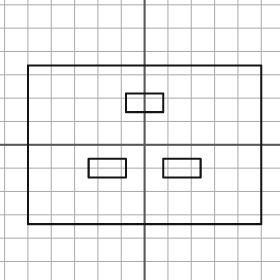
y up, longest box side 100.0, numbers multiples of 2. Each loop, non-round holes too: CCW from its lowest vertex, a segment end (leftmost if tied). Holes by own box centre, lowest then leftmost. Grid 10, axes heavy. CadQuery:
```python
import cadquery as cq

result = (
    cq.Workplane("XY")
    .moveTo(-50.0, -34.0)
    .lineTo(50.0, -34.0)
    .lineTo(50.0, 34.0)
    .lineTo(-50.0, 34.0)
    .close()
    .moveTo(-24.0, -14.0)
    .lineTo(-8.0, -14.0)
    .lineTo(-8.0, -6.0)
    .lineTo(-24.0, -6.0)
    .close()
    .moveTo(8.0, -14.0)
    .lineTo(24.0, -14.0)
    .lineTo(24.0, -6.0)
    .lineTo(8.0, -6.0)
    .close()
    .moveTo(-8.0, 14.0)
    .lineTo(8.0, 14.0)
    .lineTo(8.0, 22.0)
    .lineTo(-8.0, 22.0)
    .close()
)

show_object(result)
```